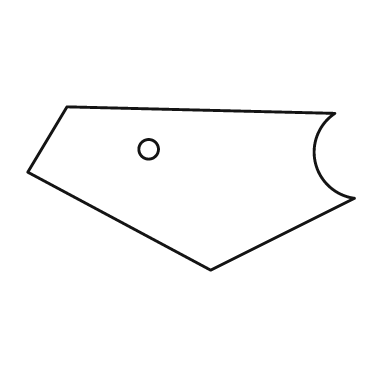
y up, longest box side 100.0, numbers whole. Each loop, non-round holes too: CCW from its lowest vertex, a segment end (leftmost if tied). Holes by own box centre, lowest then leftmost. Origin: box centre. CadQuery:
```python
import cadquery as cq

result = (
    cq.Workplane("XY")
    .moveTo(6.0, -25.0)
    .lineTo(50.0, -3.0)
    .threePointArc((38.0, 8.0), (44.0, 23.0))
    .lineTo(-38.0, 25.0)
    .lineTo(-50.0, 5.0)
    .close()
    .moveTo(-13.0, 12.0)
    .circle(3.0)
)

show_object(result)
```